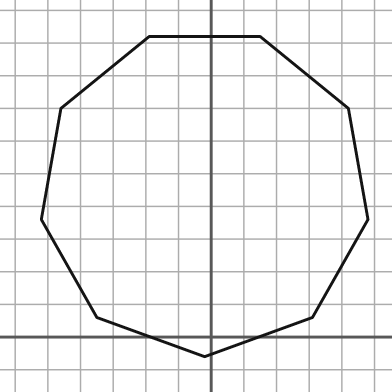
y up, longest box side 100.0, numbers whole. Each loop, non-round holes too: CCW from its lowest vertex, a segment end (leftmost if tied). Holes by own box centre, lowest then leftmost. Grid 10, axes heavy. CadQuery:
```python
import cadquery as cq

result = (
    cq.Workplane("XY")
    .moveTo(-2.0, -6.0)
    .lineTo(31.0, 6.0)
    .lineTo(48.0, 36.0)
    .lineTo(42.0, 70.0)
    .lineTo(15.0, 92.0)
    .lineTo(-19.0, 92.0)
    .lineTo(-46.0, 70.0)
    .lineTo(-52.0, 36.0)
    .lineTo(-35.0, 6.0)
    .close()
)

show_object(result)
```